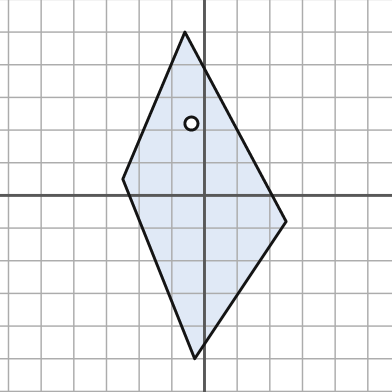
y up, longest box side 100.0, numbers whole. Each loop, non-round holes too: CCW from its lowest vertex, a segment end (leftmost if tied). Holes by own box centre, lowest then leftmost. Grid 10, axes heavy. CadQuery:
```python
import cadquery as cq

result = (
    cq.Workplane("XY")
    .moveTo(-3.0, -50.0)
    .lineTo(25.0, -8.0)
    .lineTo(-6.0, 50.0)
    .lineTo(-25.0, 5.0)
    .close()
    .moveTo(-4.0, 22.0)
    .circle(2.0)
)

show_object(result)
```